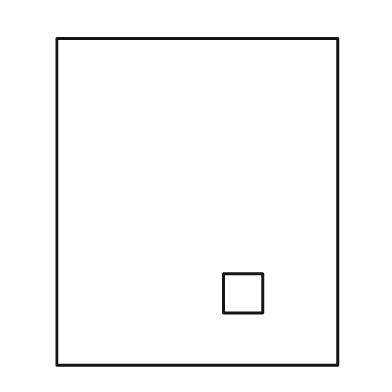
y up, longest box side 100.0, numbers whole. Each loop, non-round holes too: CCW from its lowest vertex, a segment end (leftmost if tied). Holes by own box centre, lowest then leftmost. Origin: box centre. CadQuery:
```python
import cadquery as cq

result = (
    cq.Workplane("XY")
    .moveTo(-43.0, -50.0)
    .lineTo(43.0, -50.0)
    .lineTo(43.0, 50.0)
    .lineTo(-43.0, 50.0)
    .close()
    .moveTo(8.0, -34.0)
    .lineTo(20.0, -34.0)
    .lineTo(20.0, -22.0)
    .lineTo(8.0, -22.0)
    .close()
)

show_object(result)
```